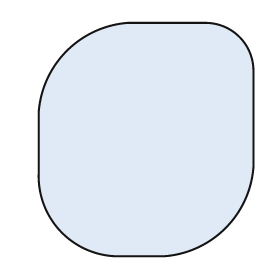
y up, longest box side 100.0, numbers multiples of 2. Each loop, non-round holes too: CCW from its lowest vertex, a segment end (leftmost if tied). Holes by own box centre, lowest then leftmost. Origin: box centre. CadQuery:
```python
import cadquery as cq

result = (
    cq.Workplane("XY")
    .moveTo(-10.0, -50.0)
    .lineTo(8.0, -50.0)
    .threePointArc((34.0, -38.0), (46.0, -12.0))
    .lineTo(46.0, 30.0)
    .threePointArc((40.0, 44.0), (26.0, 50.0))
    .lineTo(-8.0, 50.0)
    .threePointArc((-34.0, 38.0), (-46.0, 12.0))
    .lineTo(-46.0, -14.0)
    .threePointArc((-36.0, -40.0), (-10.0, -50.0))
    .close()
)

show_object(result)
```